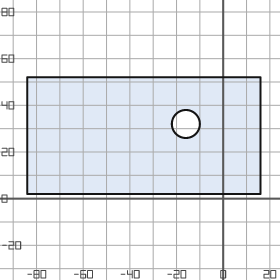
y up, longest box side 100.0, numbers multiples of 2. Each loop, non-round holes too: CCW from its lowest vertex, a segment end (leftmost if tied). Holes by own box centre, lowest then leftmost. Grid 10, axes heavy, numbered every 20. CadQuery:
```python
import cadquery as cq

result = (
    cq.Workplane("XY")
    .moveTo(-84.0, 2.0)
    .lineTo(16.0, 2.0)
    .lineTo(16.0, 52.0)
    .lineTo(-84.0, 52.0)
    .close()
    .moveTo(-16.0, 32.0)
    .circle(6.0)
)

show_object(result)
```